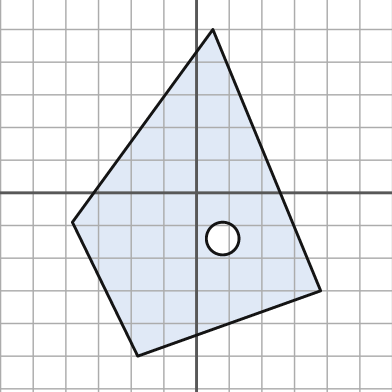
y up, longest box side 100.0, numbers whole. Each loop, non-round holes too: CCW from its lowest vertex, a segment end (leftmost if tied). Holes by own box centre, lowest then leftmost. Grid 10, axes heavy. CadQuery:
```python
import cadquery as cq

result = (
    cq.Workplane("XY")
    .moveTo(-18.0, -50.0)
    .lineTo(38.0, -30.0)
    .lineTo(5.0, 50.0)
    .lineTo(-38.0, -9.0)
    .close()
    .moveTo(8.0, -14.0)
    .circle(5.0)
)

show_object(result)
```